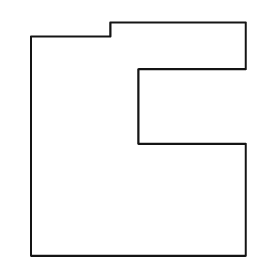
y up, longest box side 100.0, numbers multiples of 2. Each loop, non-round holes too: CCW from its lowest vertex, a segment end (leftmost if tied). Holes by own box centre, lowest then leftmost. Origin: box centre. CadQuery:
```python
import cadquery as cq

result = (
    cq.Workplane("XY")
    .moveTo(-46.0, -50.0)
    .lineTo(46.0, -50.0)
    .lineTo(46.0, -2.0)
    .lineTo(0.0, -2.0)
    .lineTo(0.0, 30.0)
    .lineTo(46.0, 30.0)
    .lineTo(46.0, 50.0)
    .lineTo(-12.0, 50.0)
    .lineTo(-12.0, 44.0)
    .lineTo(-46.0, 44.0)
    .close()
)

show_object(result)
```